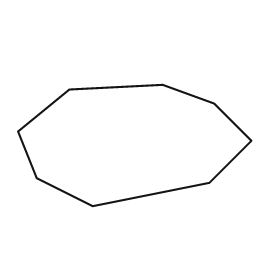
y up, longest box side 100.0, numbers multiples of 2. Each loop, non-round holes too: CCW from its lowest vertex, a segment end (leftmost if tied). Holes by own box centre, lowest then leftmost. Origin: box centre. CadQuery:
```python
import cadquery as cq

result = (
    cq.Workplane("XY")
    .moveTo(-18.0, -26.0)
    .lineTo(32.0, -16.0)
    .lineTo(50.0, 2.0)
    .lineTo(34.0, 18.0)
    .lineTo(12.0, 26.0)
    .lineTo(-28.0, 24.0)
    .lineTo(-50.0, 6.0)
    .lineTo(-42.0, -14.0)
    .close()
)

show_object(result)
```